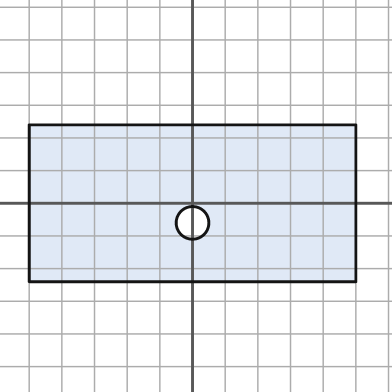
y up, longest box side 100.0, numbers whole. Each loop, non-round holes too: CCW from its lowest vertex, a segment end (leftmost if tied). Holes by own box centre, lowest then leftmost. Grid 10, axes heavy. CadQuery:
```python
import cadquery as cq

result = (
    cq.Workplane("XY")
    .moveTo(-50.0, -24.0)
    .lineTo(50.0, -24.0)
    .lineTo(50.0, 24.0)
    .lineTo(-50.0, 24.0)
    .close()
    .moveTo(0.0, -6.0)
    .circle(5.0)
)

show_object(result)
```